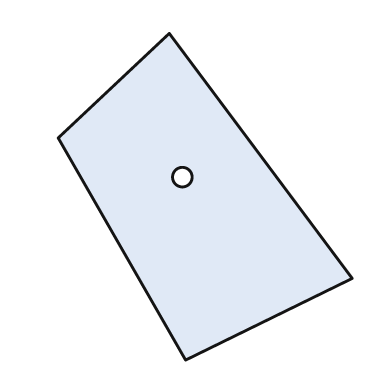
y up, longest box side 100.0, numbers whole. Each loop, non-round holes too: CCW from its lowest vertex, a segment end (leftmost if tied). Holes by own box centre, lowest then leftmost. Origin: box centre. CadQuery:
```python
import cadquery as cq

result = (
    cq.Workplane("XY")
    .moveTo(-6.0, -50.0)
    .lineTo(45.0, -25.0)
    .lineTo(-11.0, 50.0)
    .lineTo(-45.0, 18.0)
    .close()
    .moveTo(-7.0, 6.0)
    .circle(3.0)
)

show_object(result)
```